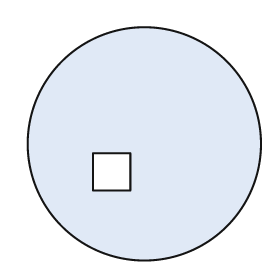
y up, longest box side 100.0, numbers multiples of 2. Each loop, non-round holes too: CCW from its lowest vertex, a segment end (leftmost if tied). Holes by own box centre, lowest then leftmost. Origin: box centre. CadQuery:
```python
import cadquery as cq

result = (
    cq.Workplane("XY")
    .moveTo(0.0, 0.0)
    .circle(50.0)
    .moveTo(-22.0, -20.0)
    .lineTo(-6.0, -20.0)
    .lineTo(-6.0, -4.0)
    .lineTo(-22.0, -4.0)
    .close()
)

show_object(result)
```